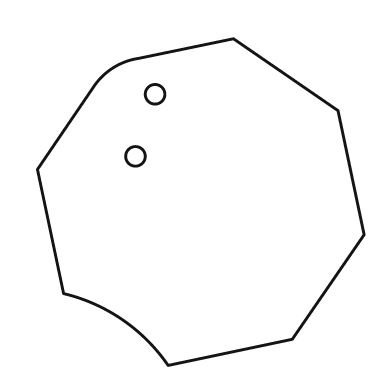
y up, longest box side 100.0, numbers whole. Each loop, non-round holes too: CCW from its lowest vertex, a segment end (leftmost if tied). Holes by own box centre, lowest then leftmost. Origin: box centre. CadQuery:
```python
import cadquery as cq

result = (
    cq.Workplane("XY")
    .moveTo(-10.0, -50.0)
    .lineTo(28.0, -42.0)
    .lineTo(50.0, -10.0)
    .lineTo(42.0, 28.0)
    .lineTo(10.0, 50.0)
    .lineTo(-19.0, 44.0)
    .threePointArc((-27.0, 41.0), (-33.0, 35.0))
    .lineTo(-50.0, 10.0)
    .lineTo(-42.0, -28.0)
    .threePointArc((-24.0, -36.0), (-10.0, -50.0))
    .close()
    .moveTo(-20.0, 14.0)
    .circle(3.0)
    .moveTo(-14.0, 33.0)
    .circle(3.0)
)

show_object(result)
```